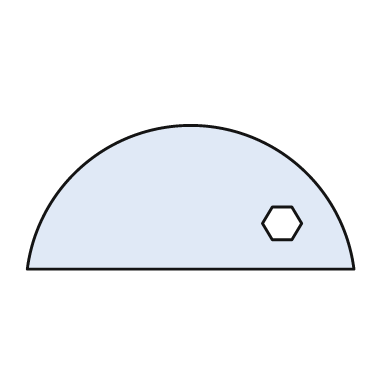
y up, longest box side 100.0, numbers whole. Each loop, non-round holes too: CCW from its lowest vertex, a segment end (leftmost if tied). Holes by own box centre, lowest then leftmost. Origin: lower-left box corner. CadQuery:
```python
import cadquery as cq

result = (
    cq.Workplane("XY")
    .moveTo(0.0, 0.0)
    .lineTo(100.0, 0.0)
    .threePointArc((50.0, 44.0), (0.0, 0.0))
    .close()
    .moveTo(75.0, 9.0)
    .lineTo(81.0, 9.0)
    .lineTo(84.0, 14.0)
    .lineTo(81.0, 19.0)
    .lineTo(75.0, 19.0)
    .lineTo(72.0, 14.0)
    .close()
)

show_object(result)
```